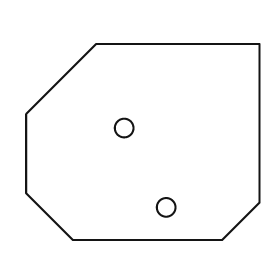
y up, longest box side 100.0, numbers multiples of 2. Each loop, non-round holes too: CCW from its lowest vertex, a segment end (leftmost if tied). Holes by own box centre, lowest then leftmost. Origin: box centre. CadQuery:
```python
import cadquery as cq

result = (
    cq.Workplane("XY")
    .moveTo(-30.0, -42.0)
    .lineTo(34.0, -42.0)
    .lineTo(50.0, -26.0)
    .lineTo(50.0, 42.0)
    .lineTo(-20.0, 42.0)
    .lineTo(-50.0, 12.0)
    .lineTo(-50.0, -22.0)
    .close()
    .moveTo(10.0, -28.0)
    .circle(4.0)
    .moveTo(-8.0, 6.0)
    .circle(4.0)
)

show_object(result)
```